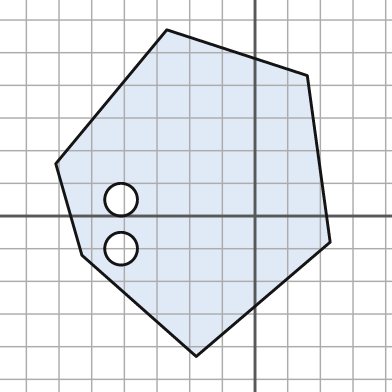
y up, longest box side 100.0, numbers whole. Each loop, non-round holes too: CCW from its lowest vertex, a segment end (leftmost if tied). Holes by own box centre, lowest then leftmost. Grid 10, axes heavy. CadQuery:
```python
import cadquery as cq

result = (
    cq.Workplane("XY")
    .moveTo(-18.0, -43.0)
    .lineTo(23.0, -8.0)
    .lineTo(16.0, 43.0)
    .lineTo(-27.0, 57.0)
    .lineTo(-61.0, 16.0)
    .lineTo(-53.0, -12.0)
    .close()
    .moveTo(-41.0, -10.0)
    .circle(5.0)
    .moveTo(-41.0, 5.0)
    .circle(5.0)
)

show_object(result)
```